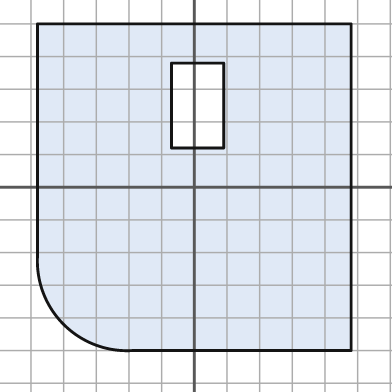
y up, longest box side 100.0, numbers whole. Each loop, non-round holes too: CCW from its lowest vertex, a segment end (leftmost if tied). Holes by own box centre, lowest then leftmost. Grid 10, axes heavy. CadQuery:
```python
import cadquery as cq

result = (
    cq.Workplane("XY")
    .moveTo(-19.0, -50.0)
    .lineTo(48.0, -50.0)
    .lineTo(48.0, 50.0)
    .lineTo(-48.0, 50.0)
    .lineTo(-48.0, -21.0)
    .threePointArc((-40.0, -42.0), (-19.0, -50.0))
    .close()
    .moveTo(-7.0, 12.0)
    .lineTo(9.0, 12.0)
    .lineTo(9.0, 38.0)
    .lineTo(-7.0, 38.0)
    .close()
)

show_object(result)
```